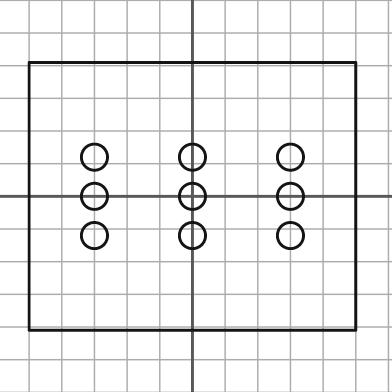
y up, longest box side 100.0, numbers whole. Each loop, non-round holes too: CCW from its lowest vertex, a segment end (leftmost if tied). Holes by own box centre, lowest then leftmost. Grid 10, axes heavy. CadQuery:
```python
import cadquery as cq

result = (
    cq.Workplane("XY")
    .moveTo(-50.0, -41.0)
    .lineTo(50.0, -41.0)
    .lineTo(50.0, 41.0)
    .lineTo(-50.0, 41.0)
    .close()
    .moveTo(-30.0, -12.0)
    .circle(4.0)
    .moveTo(0.0, -12.0)
    .circle(4.0)
    .moveTo(30.0, -12.0)
    .circle(4.0)
    .moveTo(-30.0, 0.0)
    .circle(4.0)
    .moveTo(0.0, 0.0)
    .circle(4.0)
    .moveTo(30.0, 0.0)
    .circle(4.0)
    .moveTo(-30.0, 12.0)
    .circle(4.0)
    .moveTo(0.0, 12.0)
    .circle(4.0)
    .moveTo(30.0, 12.0)
    .circle(4.0)
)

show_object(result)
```